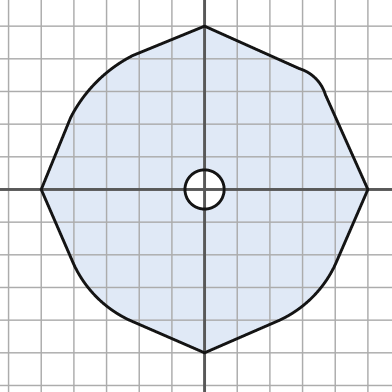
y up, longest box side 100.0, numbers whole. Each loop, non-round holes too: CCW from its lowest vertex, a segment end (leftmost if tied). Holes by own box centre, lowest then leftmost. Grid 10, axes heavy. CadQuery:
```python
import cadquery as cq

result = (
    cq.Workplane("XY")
    .moveTo(0.0, -50.0)
    .lineTo(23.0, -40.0)
    .threePointArc((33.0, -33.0), (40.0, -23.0))
    .lineTo(50.0, 0.0)
    .lineTo(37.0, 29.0)
    .threePointArc((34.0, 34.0), (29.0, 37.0))
    .lineTo(0.0, 50.0)
    .lineTo(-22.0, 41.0)
    .threePointArc((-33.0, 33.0), (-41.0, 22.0))
    .lineTo(-50.0, 0.0)
    .lineTo(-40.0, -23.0)
    .threePointArc((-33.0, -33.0), (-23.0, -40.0))
    .close()
    .moveTo(0.0, 0.0)
    .circle(6.0)
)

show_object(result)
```